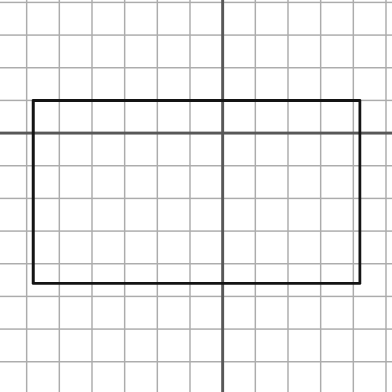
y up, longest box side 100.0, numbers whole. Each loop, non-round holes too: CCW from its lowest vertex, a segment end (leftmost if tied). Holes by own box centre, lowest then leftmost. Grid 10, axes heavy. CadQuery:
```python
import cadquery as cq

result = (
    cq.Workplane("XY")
    .moveTo(-58.0, -46.0)
    .lineTo(42.0, -46.0)
    .lineTo(42.0, 10.0)
    .lineTo(-58.0, 10.0)
    .close()
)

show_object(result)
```